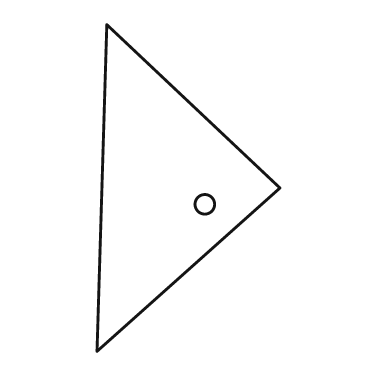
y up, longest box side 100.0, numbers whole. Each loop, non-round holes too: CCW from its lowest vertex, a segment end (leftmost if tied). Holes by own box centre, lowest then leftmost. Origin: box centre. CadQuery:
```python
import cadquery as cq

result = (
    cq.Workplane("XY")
    .moveTo(-28.0, -50.0)
    .lineTo(28.0, 0.0)
    .lineTo(-25.0, 50.0)
    .close()
    .moveTo(5.0, -5.0)
    .circle(3.0)
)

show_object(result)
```